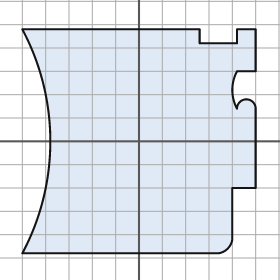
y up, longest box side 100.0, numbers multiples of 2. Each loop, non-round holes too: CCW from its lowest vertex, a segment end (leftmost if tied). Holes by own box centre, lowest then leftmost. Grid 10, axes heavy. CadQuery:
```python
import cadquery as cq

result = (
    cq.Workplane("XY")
    .moveTo(-50.0, -48.0)
    .lineTo(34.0, -48.0)
    .threePointArc((38.0, -46.0), (40.0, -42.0))
    .lineTo(40.0, -20.0)
    .lineTo(50.0, -20.0)
    .lineTo(50.0, 14.0)
    .threePointArc((46.0, 18.0), (42.0, 14.0))
    .threePointArc((40.0, 22.0), (42.0, 30.0))
    .lineTo(50.0, 30.0)
    .lineTo(50.0, 48.0)
    .lineTo(42.0, 48.0)
    .lineTo(42.0, 42.0)
    .lineTo(26.0, 42.0)
    .lineTo(26.0, 48.0)
    .lineTo(-50.0, 48.0)
    .threePointArc((-38.0, 0.0), (-50.0, -48.0))
    .close()
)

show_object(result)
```